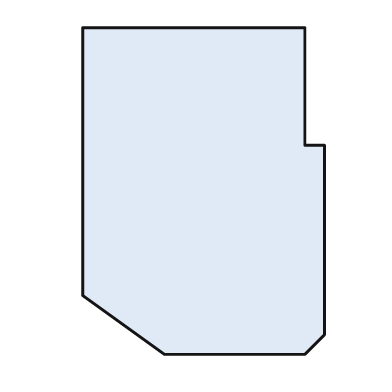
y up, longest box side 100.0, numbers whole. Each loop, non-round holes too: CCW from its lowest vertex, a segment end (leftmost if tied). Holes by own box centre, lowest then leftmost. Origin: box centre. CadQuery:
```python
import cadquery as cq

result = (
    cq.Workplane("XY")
    .moveTo(-12.0, -50.0)
    .lineTo(31.0, -50.0)
    .lineTo(37.0, -44.0)
    .lineTo(37.0, 14.0)
    .lineTo(31.0, 14.0)
    .lineTo(31.0, 50.0)
    .lineTo(-37.0, 50.0)
    .lineTo(-37.0, -32.0)
    .close()
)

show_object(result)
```